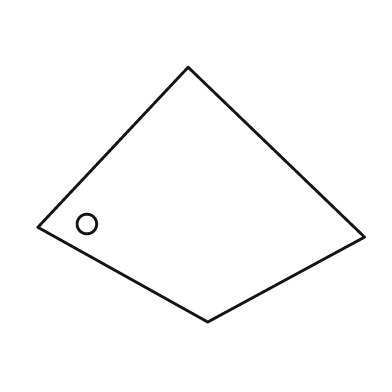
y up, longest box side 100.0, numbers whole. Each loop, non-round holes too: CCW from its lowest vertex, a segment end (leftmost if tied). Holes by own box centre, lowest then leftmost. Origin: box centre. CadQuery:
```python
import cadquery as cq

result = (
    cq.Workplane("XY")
    .moveTo(2.0, -39.0)
    .lineTo(50.0, -13.0)
    .lineTo(-4.0, 39.0)
    .lineTo(-50.0, -10.0)
    .close()
    .moveTo(-35.0, -9.0)
    .circle(3.0)
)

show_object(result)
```